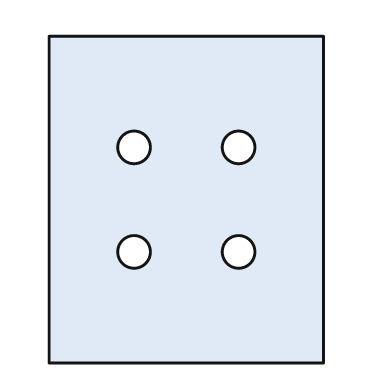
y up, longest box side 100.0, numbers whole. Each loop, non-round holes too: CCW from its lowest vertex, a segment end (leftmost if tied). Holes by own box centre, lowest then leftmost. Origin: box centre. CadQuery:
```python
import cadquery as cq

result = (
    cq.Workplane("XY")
    .moveTo(-42.0, -50.0)
    .lineTo(42.0, -50.0)
    .lineTo(42.0, 50.0)
    .lineTo(-42.0, 50.0)
    .close()
    .moveTo(-16.0, -16.0)
    .circle(5.0)
    .moveTo(16.0, -16.0)
    .circle(5.0)
    .moveTo(-16.0, 16.0)
    .circle(5.0)
    .moveTo(16.0, 16.0)
    .circle(5.0)
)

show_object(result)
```